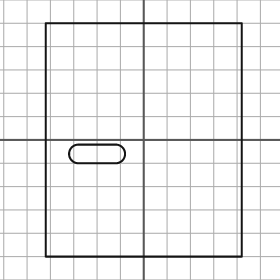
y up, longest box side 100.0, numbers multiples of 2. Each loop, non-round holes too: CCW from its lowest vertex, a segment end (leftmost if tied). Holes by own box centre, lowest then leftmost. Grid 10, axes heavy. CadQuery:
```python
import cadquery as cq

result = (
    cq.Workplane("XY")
    .moveTo(-42.0, -50.0)
    .lineTo(42.0, -50.0)
    .lineTo(42.0, 50.0)
    .lineTo(-42.0, 50.0)
    .close()
    .moveTo(-28.0, -10.0)
    .lineTo(-12.0, -10.0)
    .threePointArc((-8.0, -6.0), (-12.0, -2.0))
    .lineTo(-28.0, -2.0)
    .threePointArc((-32.0, -6.0), (-28.0, -10.0))
    .close()
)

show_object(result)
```